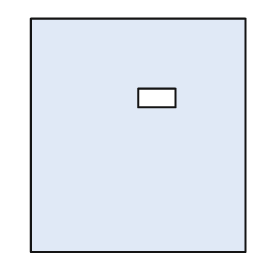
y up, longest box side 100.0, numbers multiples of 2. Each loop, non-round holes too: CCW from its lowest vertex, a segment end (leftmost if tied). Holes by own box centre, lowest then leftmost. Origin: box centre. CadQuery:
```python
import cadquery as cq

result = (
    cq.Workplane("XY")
    .moveTo(-46.0, -50.0)
    .lineTo(46.0, -50.0)
    .lineTo(46.0, 50.0)
    .lineTo(-46.0, 50.0)
    .close()
    .moveTo(0.0, 12.0)
    .lineTo(16.0, 12.0)
    .lineTo(16.0, 20.0)
    .lineTo(0.0, 20.0)
    .close()
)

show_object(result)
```